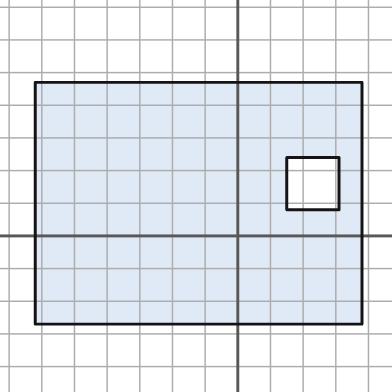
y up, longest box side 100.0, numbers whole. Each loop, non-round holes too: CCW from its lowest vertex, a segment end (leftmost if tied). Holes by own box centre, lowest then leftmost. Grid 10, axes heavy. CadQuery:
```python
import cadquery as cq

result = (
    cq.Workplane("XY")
    .moveTo(-62.0, -27.0)
    .lineTo(38.0, -27.0)
    .lineTo(38.0, 47.0)
    .lineTo(-62.0, 47.0)
    .close()
    .moveTo(15.0, 8.0)
    .lineTo(31.0, 8.0)
    .lineTo(31.0, 24.0)
    .lineTo(15.0, 24.0)
    .close()
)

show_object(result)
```